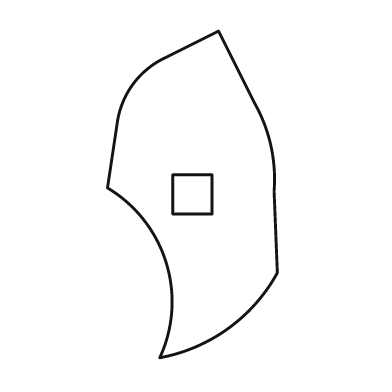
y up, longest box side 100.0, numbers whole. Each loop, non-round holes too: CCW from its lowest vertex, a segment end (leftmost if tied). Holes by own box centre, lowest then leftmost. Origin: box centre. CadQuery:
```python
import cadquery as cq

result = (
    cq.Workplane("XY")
    .moveTo(-10.0, -50.0)
    .threePointArc((11.0, -41.0), (26.0, -24.0))
    .lineTo(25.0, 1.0)
    .threePointArc((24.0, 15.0), (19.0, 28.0))
    .lineTo(8.0, 50.0)
    .lineTo(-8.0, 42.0)
    .threePointArc((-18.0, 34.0), (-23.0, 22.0))
    .lineTo(-26.0, 2.0)
    .threePointArc((-8.0, -21.0), (-10.0, -50.0))
    .close()
    .moveTo(-6.0, -6.0)
    .lineTo(6.0, -6.0)
    .lineTo(6.0, 6.0)
    .lineTo(-6.0, 6.0)
    .close()
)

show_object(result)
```